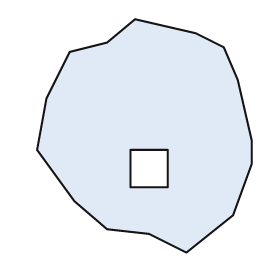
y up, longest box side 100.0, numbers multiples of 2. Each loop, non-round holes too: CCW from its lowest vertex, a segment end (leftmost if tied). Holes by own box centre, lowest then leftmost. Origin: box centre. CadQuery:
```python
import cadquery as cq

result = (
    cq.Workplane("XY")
    .moveTo(18.0, -50.0)
    .lineTo(38.0, -34.0)
    .lineTo(46.0, -12.0)
    .lineTo(46.0, -2.0)
    .lineTo(40.0, 24.0)
    .lineTo(34.0, 38.0)
    .lineTo(22.0, 44.0)
    .lineTo(-4.0, 50.0)
    .lineTo(-16.0, 40.0)
    .lineTo(-32.0, 36.0)
    .lineTo(-42.0, 16.0)
    .lineTo(-46.0, -6.0)
    .lineTo(-30.0, -28.0)
    .lineTo(-16.0, -40.0)
    .lineTo(2.0, -42.0)
    .close()
    .moveTo(-6.0, -22.0)
    .lineTo(10.0, -22.0)
    .lineTo(10.0, -6.0)
    .lineTo(-6.0, -6.0)
    .close()
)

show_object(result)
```